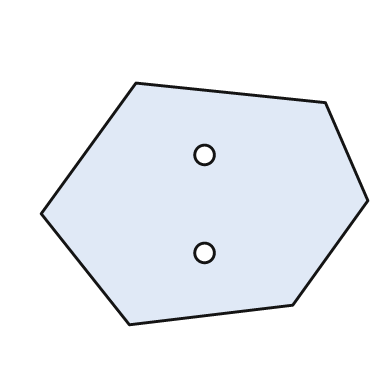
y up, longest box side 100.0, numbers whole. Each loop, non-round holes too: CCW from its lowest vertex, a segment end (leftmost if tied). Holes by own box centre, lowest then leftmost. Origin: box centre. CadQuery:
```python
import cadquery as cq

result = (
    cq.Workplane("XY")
    .moveTo(-23.0, -37.0)
    .lineTo(27.0, -31.0)
    .lineTo(50.0, 1.0)
    .lineTo(37.0, 31.0)
    .lineTo(-21.0, 37.0)
    .lineTo(-50.0, -3.0)
    .close()
    .moveTo(0.0, -15.0)
    .circle(3.0)
    .moveTo(0.0, 15.0)
    .circle(3.0)
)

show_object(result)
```